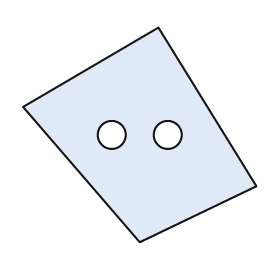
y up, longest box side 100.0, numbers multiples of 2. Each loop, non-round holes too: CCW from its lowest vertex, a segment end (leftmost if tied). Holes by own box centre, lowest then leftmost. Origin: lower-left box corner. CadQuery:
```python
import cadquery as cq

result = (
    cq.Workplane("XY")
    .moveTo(50.0, 0.0)
    .lineTo(100.0, 24.0)
    .lineTo(58.0, 92.0)
    .lineTo(0.0, 58.0)
    .close()
    .moveTo(38.0, 46.0)
    .circle(6.0)
    .moveTo(62.0, 46.0)
    .circle(6.0)
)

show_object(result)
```